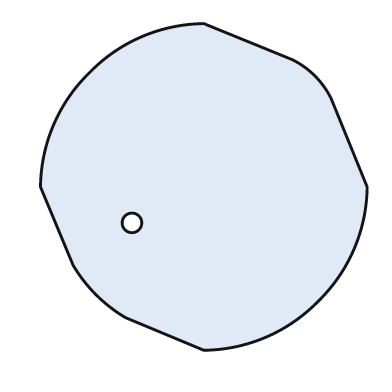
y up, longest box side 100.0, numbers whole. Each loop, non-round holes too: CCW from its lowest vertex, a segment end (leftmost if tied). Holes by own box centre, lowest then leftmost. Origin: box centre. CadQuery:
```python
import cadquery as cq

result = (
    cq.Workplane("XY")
    .moveTo(0.0, -50.0)
    .threePointArc((19.0, -46.0), (35.0, -35.0))
    .threePointArc((46.0, -19.0), (50.0, 0.0))
    .lineTo(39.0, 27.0)
    .threePointArc((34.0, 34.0), (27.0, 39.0))
    .lineTo(0.0, 50.0)
    .threePointArc((-19.0, 46.0), (-35.0, 35.0))
    .threePointArc((-46.0, 19.0), (-50.0, 0.0))
    .lineTo(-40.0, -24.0)
    .threePointArc((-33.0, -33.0), (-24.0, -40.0))
    .close()
    .moveTo(-22.0, -11.0)
    .circle(3.0)
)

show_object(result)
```